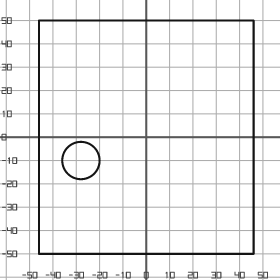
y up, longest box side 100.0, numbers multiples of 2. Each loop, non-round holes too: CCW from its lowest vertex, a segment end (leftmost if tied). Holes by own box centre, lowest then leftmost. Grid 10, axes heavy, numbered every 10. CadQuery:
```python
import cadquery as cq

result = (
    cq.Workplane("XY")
    .moveTo(-46.0, -50.0)
    .lineTo(46.0, -50.0)
    .lineTo(46.0, 50.0)
    .lineTo(-46.0, 50.0)
    .close()
    .moveTo(-28.0, -10.0)
    .circle(8.0)
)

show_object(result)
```